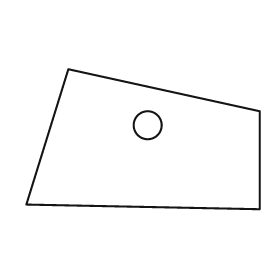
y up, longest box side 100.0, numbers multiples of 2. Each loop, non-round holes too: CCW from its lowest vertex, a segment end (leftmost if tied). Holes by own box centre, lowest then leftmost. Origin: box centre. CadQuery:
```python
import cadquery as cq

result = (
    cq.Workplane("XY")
    .moveTo(50.0, -30.0)
    .lineTo(50.0, 12.0)
    .lineTo(-32.0, 30.0)
    .lineTo(-50.0, -28.0)
    .close()
    .moveTo(2.0, 6.0)
    .circle(6.0)
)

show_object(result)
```